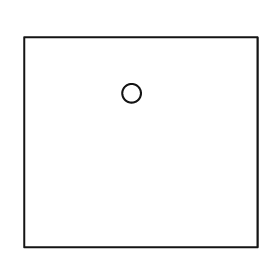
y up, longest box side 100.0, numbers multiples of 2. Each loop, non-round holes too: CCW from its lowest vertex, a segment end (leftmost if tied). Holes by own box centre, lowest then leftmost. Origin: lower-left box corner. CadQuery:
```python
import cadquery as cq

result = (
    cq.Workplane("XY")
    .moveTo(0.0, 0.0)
    .lineTo(100.0, 0.0)
    .lineTo(100.0, 90.0)
    .lineTo(0.0, 90.0)
    .close()
    .moveTo(46.0, 66.0)
    .circle(4.0)
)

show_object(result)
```